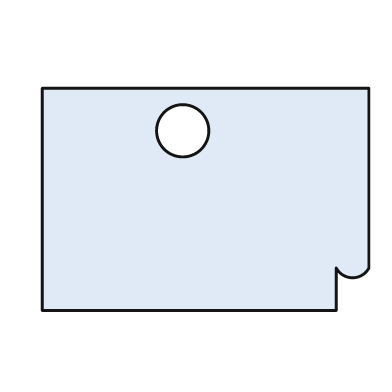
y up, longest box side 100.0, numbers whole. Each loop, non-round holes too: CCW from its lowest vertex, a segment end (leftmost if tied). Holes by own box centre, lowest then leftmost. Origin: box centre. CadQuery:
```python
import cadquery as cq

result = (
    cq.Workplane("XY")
    .moveTo(-50.0, -34.0)
    .lineTo(40.0, -34.0)
    .lineTo(40.0, -21.0)
    .threePointArc((45.0, -24.0), (50.0, -21.0))
    .lineTo(50.0, 34.0)
    .lineTo(-50.0, 34.0)
    .close()
    .moveTo(-7.0, 21.0)
    .circle(8.0)
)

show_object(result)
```